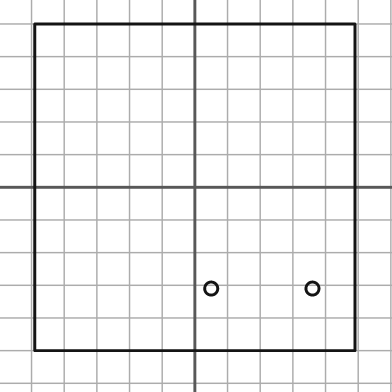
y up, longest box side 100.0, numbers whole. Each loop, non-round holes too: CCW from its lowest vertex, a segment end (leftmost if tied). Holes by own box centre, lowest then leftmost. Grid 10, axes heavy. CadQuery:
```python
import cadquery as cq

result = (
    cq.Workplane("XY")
    .moveTo(-49.0, -50.0)
    .lineTo(49.0, -50.0)
    .lineTo(49.0, 50.0)
    .lineTo(-49.0, 50.0)
    .close()
    .moveTo(5.0, -31.0)
    .circle(2.0)
    .moveTo(36.0, -31.0)
    .circle(2.0)
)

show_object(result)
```